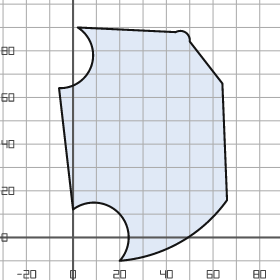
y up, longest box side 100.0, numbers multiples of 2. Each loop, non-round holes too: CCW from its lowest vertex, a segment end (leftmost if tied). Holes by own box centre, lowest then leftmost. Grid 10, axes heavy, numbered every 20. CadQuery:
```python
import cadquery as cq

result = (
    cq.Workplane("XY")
    .moveTo(20.0, -10.0)
    .threePointArc((46.0, -2.0), (66.0, 16.0))
    .lineTo(64.0, 66.0)
    .lineTo(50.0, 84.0)
    .threePointArc((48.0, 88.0), (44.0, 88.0))
    .lineTo(2.0, 90.0)
    .threePointArc((8.0, 74.0), (-6.0, 64.0))
    .lineTo(0.0, 12.0)
    .threePointArc((20.0, 10.0), (20.0, -10.0))
    .close()
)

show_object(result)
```